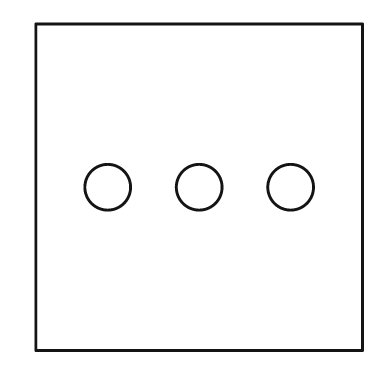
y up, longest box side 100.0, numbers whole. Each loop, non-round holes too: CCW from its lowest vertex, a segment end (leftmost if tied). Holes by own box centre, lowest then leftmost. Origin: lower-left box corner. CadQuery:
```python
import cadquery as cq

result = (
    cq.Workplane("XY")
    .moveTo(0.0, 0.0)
    .lineTo(100.0, 0.0)
    .lineTo(100.0, 100.0)
    .lineTo(0.0, 100.0)
    .close()
    .moveTo(22.0, 50.0)
    .circle(7.0)
    .moveTo(50.0, 50.0)
    .circle(7.0)
    .moveTo(78.0, 50.0)
    .circle(7.0)
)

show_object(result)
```